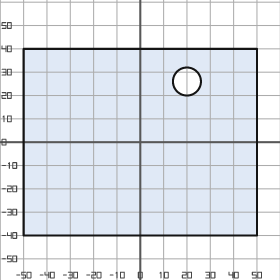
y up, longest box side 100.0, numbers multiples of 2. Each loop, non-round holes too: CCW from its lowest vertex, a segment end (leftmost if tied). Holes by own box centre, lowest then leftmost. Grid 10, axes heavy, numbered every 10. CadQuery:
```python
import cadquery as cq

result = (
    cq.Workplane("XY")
    .moveTo(-50.0, -40.0)
    .lineTo(50.0, -40.0)
    .lineTo(50.0, 40.0)
    .lineTo(-50.0, 40.0)
    .close()
    .moveTo(20.0, 26.0)
    .circle(6.0)
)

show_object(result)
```